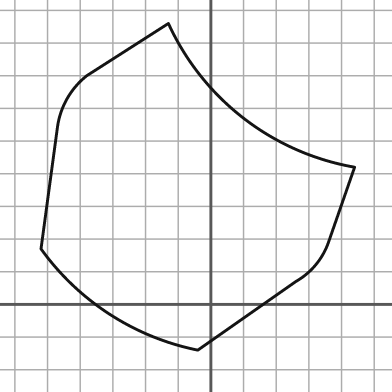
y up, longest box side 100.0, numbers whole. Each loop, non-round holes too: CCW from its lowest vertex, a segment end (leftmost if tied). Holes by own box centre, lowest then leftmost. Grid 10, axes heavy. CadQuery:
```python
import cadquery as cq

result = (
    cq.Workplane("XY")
    .moveTo(-4.0, -14.0)
    .lineTo(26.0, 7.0)
    .threePointArc((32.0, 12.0), (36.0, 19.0))
    .lineTo(44.0, 42.0)
    .threePointArc((10.0, 57.0), (-13.0, 86.0))
    .lineTo(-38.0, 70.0)
    .threePointArc((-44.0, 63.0), (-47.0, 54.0))
    .lineTo(-52.0, 17.0)
    .threePointArc((-31.0, -3.0), (-4.0, -14.0))
    .close()
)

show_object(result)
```